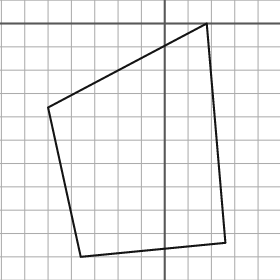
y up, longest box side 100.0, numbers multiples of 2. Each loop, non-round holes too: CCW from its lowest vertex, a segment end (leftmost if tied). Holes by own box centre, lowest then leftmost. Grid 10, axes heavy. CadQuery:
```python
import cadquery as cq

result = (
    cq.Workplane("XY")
    .moveTo(-36.0, -100.0)
    .lineTo(26.0, -94.0)
    .lineTo(18.0, 0.0)
    .lineTo(-50.0, -36.0)
    .close()
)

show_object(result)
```